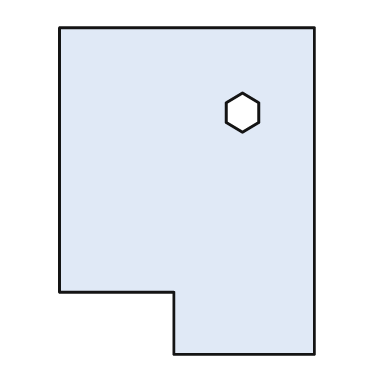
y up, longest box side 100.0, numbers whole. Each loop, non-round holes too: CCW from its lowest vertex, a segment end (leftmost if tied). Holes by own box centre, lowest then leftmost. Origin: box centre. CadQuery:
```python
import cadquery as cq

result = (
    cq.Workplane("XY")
    .moveTo(-4.0, -50.0)
    .lineTo(39.0, -50.0)
    .lineTo(39.0, 50.0)
    .lineTo(-39.0, 50.0)
    .lineTo(-39.0, -31.0)
    .lineTo(-4.0, -31.0)
    .close()
    .moveTo(17.0, 18.0)
    .lineTo(22.0, 21.0)
    .lineTo(22.0, 27.0)
    .lineTo(17.0, 30.0)
    .lineTo(12.0, 27.0)
    .lineTo(12.0, 21.0)
    .close()
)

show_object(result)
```